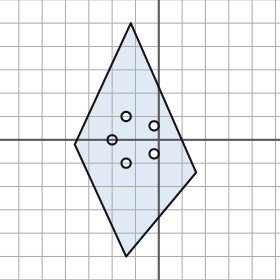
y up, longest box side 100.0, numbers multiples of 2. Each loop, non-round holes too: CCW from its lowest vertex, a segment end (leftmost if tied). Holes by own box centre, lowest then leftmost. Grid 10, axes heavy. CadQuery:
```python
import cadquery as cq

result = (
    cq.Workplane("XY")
    .moveTo(-14.0, -50.0)
    .lineTo(16.0, -14.0)
    .lineTo(-12.0, 50.0)
    .lineTo(-36.0, -2.0)
    .close()
    .moveTo(-14.0, -10.0)
    .circle(2.0)
    .moveTo(-2.0, -6.0)
    .circle(2.0)
    .moveTo(-20.0, 0.0)
    .circle(2.0)
    .moveTo(-2.0, 6.0)
    .circle(2.0)
    .moveTo(-14.0, 10.0)
    .circle(2.0)
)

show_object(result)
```